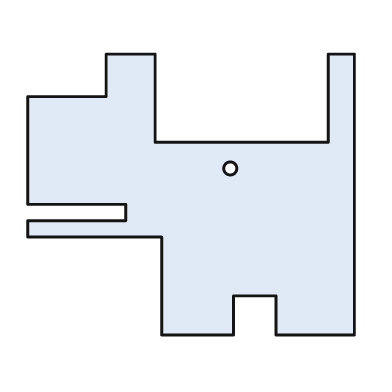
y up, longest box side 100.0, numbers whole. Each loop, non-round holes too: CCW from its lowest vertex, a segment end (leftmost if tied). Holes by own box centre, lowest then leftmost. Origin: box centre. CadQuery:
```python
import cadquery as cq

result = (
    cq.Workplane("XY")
    .moveTo(-9.0, -43.0)
    .lineTo(13.0, -43.0)
    .lineTo(13.0, -31.0)
    .lineTo(26.0, -31.0)
    .lineTo(26.0, -43.0)
    .lineTo(50.0, -43.0)
    .lineTo(50.0, 43.0)
    .lineTo(42.0, 43.0)
    .lineTo(42.0, 16.0)
    .lineTo(-11.0, 16.0)
    .lineTo(-11.0, 43.0)
    .lineTo(-26.0, 43.0)
    .lineTo(-26.0, 30.0)
    .lineTo(-50.0, 30.0)
    .lineTo(-50.0, -3.0)
    .lineTo(-20.0, -3.0)
    .lineTo(-20.0, -8.0)
    .lineTo(-50.0, -8.0)
    .lineTo(-50.0, -13.0)
    .lineTo(-9.0, -13.0)
    .close()
    .moveTo(12.0, 8.0)
    .circle(2.0)
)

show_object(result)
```